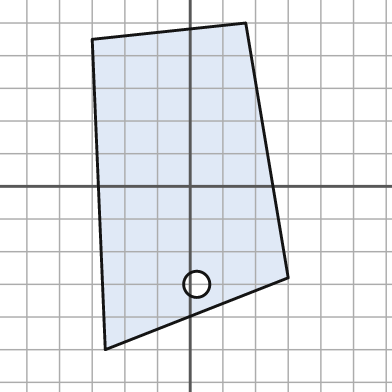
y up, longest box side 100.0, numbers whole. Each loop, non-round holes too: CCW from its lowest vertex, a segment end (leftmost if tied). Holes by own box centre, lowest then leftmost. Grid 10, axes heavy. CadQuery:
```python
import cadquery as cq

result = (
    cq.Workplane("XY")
    .moveTo(-26.0, -50.0)
    .lineTo(30.0, -28.0)
    .lineTo(17.0, 50.0)
    .lineTo(-30.0, 45.0)
    .close()
    .moveTo(2.0, -30.0)
    .circle(4.0)
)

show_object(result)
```